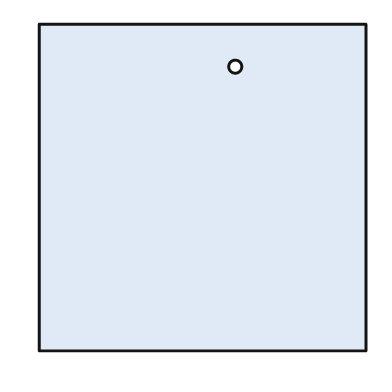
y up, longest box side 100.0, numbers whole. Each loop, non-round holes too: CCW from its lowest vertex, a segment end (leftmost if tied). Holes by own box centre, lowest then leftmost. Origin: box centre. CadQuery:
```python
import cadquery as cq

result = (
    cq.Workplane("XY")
    .moveTo(-50.0, -50.0)
    .lineTo(50.0, -50.0)
    .lineTo(50.0, 50.0)
    .lineTo(-50.0, 50.0)
    .close()
    .moveTo(10.0, 37.0)
    .circle(2.0)
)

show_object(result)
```